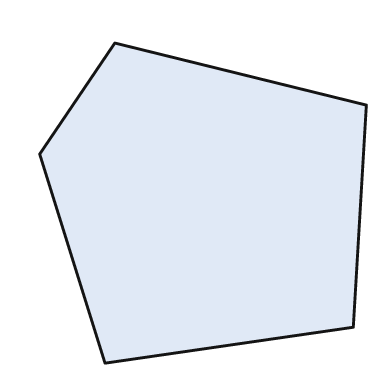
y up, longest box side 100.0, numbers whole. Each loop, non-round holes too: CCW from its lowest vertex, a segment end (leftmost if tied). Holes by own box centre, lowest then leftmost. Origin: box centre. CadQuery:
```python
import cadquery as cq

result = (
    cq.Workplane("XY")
    .moveTo(-30.0, -49.0)
    .lineTo(46.0, -38.0)
    .lineTo(50.0, 30.0)
    .lineTo(-27.0, 49.0)
    .lineTo(-50.0, 15.0)
    .close()
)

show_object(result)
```